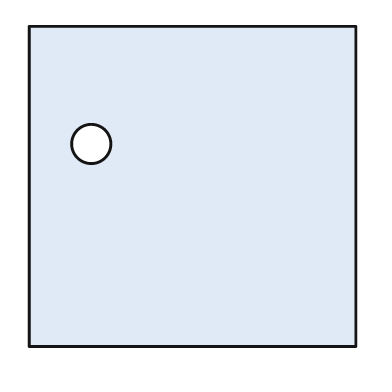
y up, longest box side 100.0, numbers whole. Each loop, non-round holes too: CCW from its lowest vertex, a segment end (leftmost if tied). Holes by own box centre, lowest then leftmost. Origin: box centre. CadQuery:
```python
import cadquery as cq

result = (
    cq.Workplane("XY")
    .moveTo(-50.0, -49.0)
    .lineTo(50.0, -49.0)
    .lineTo(50.0, 49.0)
    .lineTo(-50.0, 49.0)
    .close()
    .moveTo(-31.0, 13.0)
    .circle(6.0)
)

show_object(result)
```